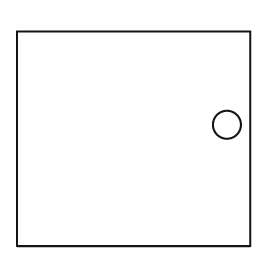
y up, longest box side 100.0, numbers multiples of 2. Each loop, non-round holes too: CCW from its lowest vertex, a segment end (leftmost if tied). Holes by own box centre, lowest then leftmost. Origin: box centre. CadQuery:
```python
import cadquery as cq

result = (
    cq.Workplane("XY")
    .moveTo(-50.0, -46.0)
    .lineTo(50.0, -46.0)
    .lineTo(50.0, 46.0)
    .lineTo(-50.0, 46.0)
    .close()
    .moveTo(40.0, 6.0)
    .circle(6.0)
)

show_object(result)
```